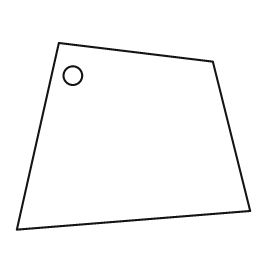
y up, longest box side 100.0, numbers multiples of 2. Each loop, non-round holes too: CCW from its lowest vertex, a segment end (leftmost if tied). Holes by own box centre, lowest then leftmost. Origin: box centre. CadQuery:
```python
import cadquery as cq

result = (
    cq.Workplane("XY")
    .moveTo(-50.0, -40.0)
    .lineTo(50.0, -32.0)
    .lineTo(34.0, 32.0)
    .lineTo(-32.0, 40.0)
    .close()
    .moveTo(-26.0, 26.0)
    .circle(4.0)
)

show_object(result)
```